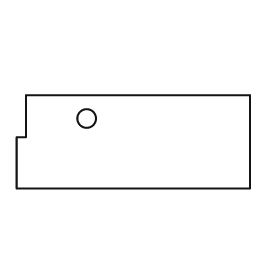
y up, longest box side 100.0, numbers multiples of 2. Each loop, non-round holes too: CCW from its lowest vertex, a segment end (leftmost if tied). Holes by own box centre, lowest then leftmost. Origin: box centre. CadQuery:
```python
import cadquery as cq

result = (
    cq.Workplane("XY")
    .moveTo(-50.0, -20.0)
    .lineTo(50.0, -20.0)
    .lineTo(50.0, 20.0)
    .lineTo(-46.0, 20.0)
    .lineTo(-46.0, 2.0)
    .lineTo(-50.0, 2.0)
    .close()
    .moveTo(-20.0, 10.0)
    .circle(4.0)
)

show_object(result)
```